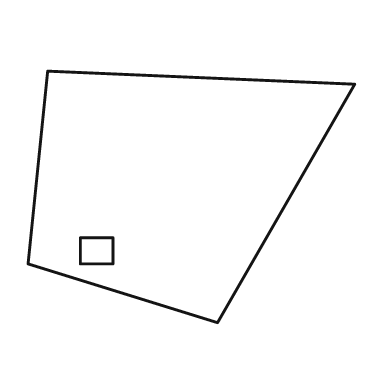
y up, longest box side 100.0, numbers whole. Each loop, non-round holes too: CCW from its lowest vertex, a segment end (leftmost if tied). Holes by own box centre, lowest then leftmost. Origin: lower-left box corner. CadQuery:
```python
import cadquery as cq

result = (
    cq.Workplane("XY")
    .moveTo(58.0, 0.0)
    .lineTo(100.0, 73.0)
    .lineTo(6.0, 77.0)
    .lineTo(0.0, 18.0)
    .close()
    .moveTo(16.0, 18.0)
    .lineTo(26.0, 18.0)
    .lineTo(26.0, 26.0)
    .lineTo(16.0, 26.0)
    .close()
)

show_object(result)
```